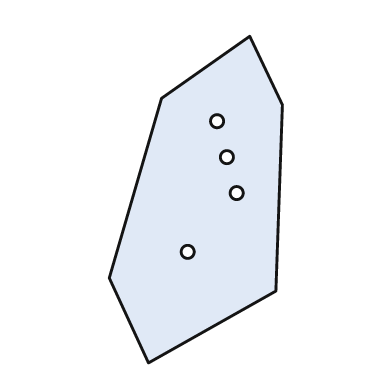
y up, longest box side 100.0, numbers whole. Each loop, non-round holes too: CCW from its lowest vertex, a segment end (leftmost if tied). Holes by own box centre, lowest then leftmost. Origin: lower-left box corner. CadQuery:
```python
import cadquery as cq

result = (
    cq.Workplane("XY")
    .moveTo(12.0, 0.0)
    .lineTo(51.0, 22.0)
    .lineTo(53.0, 79.0)
    .lineTo(43.0, 100.0)
    .lineTo(16.0, 81.0)
    .lineTo(0.0, 26.0)
    .close()
    .moveTo(24.0, 34.0)
    .circle(2.0)
    .moveTo(39.0, 52.0)
    .circle(2.0)
    .moveTo(36.0, 63.0)
    .circle(2.0)
    .moveTo(33.0, 74.0)
    .circle(2.0)
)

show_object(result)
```